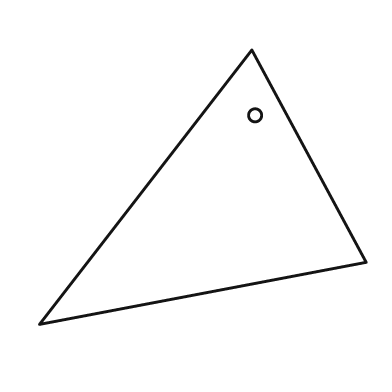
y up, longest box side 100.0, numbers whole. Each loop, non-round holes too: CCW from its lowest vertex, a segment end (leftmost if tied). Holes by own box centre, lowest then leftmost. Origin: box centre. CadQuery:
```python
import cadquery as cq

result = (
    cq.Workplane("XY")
    .moveTo(-50.0, -42.0)
    .lineTo(50.0, -23.0)
    .lineTo(15.0, 42.0)
    .close()
    .moveTo(16.0, 22.0)
    .circle(2.0)
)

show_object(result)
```